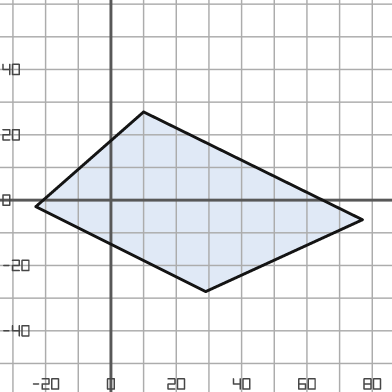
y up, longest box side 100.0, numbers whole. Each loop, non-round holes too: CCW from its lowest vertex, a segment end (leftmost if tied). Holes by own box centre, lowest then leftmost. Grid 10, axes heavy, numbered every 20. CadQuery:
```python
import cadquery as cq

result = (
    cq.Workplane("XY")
    .moveTo(29.0, -28.0)
    .lineTo(77.0, -6.0)
    .lineTo(10.0, 27.0)
    .lineTo(-23.0, -2.0)
    .close()
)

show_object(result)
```